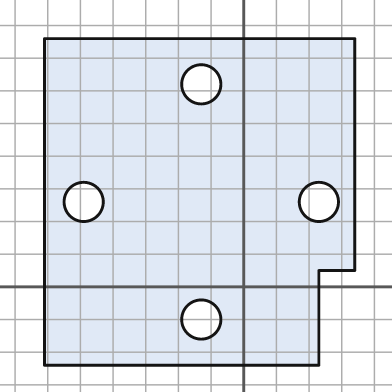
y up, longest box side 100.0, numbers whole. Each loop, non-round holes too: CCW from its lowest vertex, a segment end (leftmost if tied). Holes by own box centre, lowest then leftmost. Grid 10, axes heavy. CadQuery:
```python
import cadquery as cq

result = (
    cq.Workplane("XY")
    .moveTo(-61.0, -24.0)
    .lineTo(23.0, -24.0)
    .lineTo(23.0, 5.0)
    .lineTo(34.0, 5.0)
    .lineTo(34.0, 76.0)
    .lineTo(-61.0, 76.0)
    .close()
    .moveTo(-13.0, -10.0)
    .circle(6.0)
    .moveTo(-49.0, 26.0)
    .circle(6.0)
    .moveTo(23.0, 26.0)
    .circle(6.0)
    .moveTo(-13.0, 62.0)
    .circle(6.0)
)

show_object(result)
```